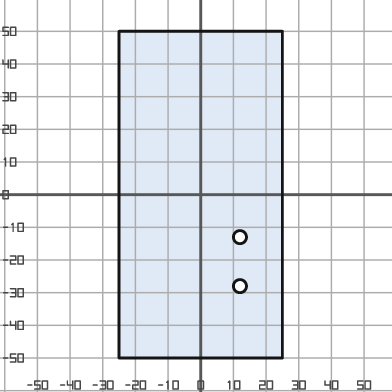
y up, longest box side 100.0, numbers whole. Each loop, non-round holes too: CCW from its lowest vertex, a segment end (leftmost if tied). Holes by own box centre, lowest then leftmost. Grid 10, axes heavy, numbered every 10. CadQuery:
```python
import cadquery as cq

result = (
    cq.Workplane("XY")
    .moveTo(-25.0, -50.0)
    .lineTo(25.0, -50.0)
    .lineTo(25.0, 50.0)
    .lineTo(-25.0, 50.0)
    .close()
    .moveTo(12.0, -28.0)
    .circle(2.0)
    .moveTo(12.0, -13.0)
    .circle(2.0)
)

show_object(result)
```